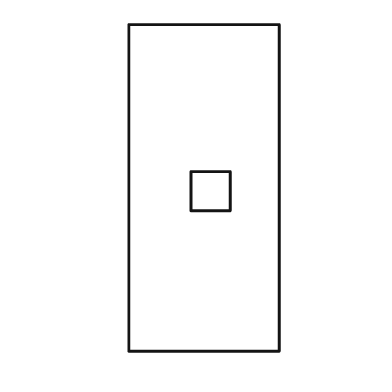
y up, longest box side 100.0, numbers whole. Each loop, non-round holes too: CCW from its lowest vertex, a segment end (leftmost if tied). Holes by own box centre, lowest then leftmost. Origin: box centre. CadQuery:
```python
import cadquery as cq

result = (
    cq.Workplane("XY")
    .moveTo(-23.0, -50.0)
    .lineTo(23.0, -50.0)
    .lineTo(23.0, 50.0)
    .lineTo(-23.0, 50.0)
    .close()
    .moveTo(-4.0, -7.0)
    .lineTo(8.0, -7.0)
    .lineTo(8.0, 5.0)
    .lineTo(-4.0, 5.0)
    .close()
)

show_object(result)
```